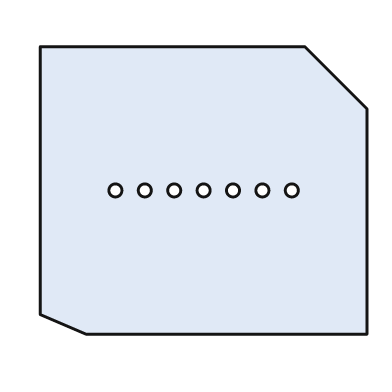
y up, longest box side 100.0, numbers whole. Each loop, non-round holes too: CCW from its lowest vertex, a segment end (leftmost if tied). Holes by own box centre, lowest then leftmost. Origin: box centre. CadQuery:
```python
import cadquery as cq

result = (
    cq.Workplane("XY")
    .moveTo(-36.0, -44.0)
    .lineTo(50.0, -44.0)
    .lineTo(50.0, 25.0)
    .lineTo(31.0, 44.0)
    .lineTo(-50.0, 44.0)
    .lineTo(-50.0, -38.0)
    .close()
    .moveTo(-27.0, 0.0)
    .circle(2.0)
    .moveTo(-18.0, 0.0)
    .circle(2.0)
    .moveTo(-9.0, 0.0)
    .circle(2.0)
    .moveTo(0.0, 0.0)
    .circle(2.0)
    .moveTo(9.0, 0.0)
    .circle(2.0)
    .moveTo(18.0, 0.0)
    .circle(2.0)
    .moveTo(27.0, 0.0)
    .circle(2.0)
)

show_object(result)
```